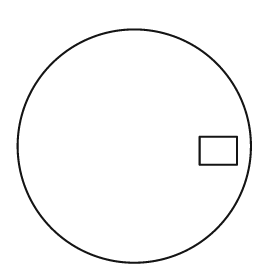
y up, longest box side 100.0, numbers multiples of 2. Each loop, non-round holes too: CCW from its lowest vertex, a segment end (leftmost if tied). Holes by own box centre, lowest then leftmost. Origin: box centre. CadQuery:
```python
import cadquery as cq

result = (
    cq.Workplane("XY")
    .moveTo(0.0, 0.0)
    .circle(50.0)
    .moveTo(28.0, -8.0)
    .lineTo(44.0, -8.0)
    .lineTo(44.0, 4.0)
    .lineTo(28.0, 4.0)
    .close()
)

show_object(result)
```